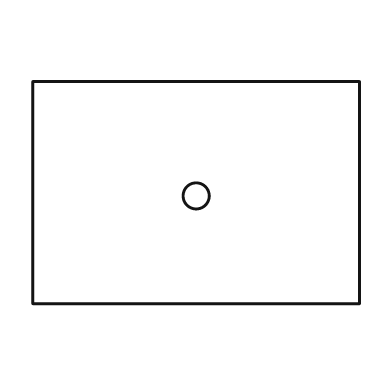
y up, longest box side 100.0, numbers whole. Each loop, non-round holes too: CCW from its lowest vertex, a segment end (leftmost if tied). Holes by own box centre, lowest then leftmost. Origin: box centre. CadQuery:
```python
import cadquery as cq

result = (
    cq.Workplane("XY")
    .moveTo(-50.0, -34.0)
    .lineTo(50.0, -34.0)
    .lineTo(50.0, 34.0)
    .lineTo(-50.0, 34.0)
    .close()
    .moveTo(0.0, -1.0)
    .circle(4.0)
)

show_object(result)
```